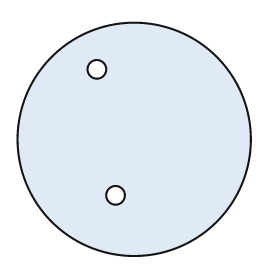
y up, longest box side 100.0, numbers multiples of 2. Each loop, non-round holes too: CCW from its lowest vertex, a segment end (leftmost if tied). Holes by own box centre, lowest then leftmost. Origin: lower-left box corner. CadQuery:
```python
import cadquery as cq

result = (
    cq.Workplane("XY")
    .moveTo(50.0, 50.0)
    .circle(50.0)
    .moveTo(42.0, 26.0)
    .circle(4.0)
    .moveTo(34.0, 80.0)
    .circle(4.0)
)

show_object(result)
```